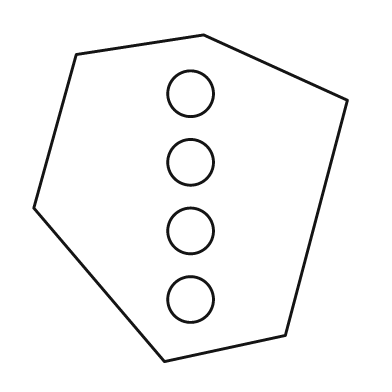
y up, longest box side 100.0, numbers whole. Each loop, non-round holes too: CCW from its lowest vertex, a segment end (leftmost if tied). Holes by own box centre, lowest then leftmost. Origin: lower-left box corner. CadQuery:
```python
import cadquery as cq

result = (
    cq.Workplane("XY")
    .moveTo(40.0, 0.0)
    .lineTo(77.0, 8.0)
    .lineTo(96.0, 80.0)
    .lineTo(52.0, 100.0)
    .lineTo(13.0, 94.0)
    .lineTo(0.0, 47.0)
    .close()
    .moveTo(48.0, 19.0)
    .circle(7.0)
    .moveTo(48.0, 40.0)
    .circle(7.0)
    .moveTo(48.0, 61.0)
    .circle(7.0)
    .moveTo(48.0, 82.0)
    .circle(7.0)
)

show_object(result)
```